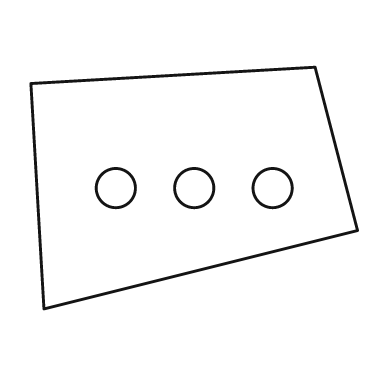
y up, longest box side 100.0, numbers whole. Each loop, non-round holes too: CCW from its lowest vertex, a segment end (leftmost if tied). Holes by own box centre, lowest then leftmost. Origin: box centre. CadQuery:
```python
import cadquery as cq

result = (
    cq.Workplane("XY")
    .moveTo(-46.0, -37.0)
    .lineTo(50.0, -13.0)
    .lineTo(37.0, 37.0)
    .lineTo(-50.0, 32.0)
    .close()
    .moveTo(-24.0, 0.0)
    .circle(6.0)
    .moveTo(0.0, 0.0)
    .circle(6.0)
    .moveTo(24.0, 0.0)
    .circle(6.0)
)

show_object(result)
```